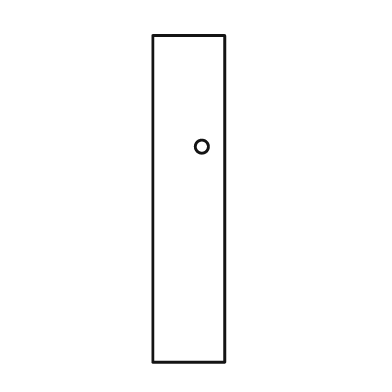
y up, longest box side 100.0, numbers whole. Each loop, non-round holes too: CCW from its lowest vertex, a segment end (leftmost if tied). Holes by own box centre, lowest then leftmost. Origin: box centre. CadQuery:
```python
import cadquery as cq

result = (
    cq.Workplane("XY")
    .moveTo(-11.0, -50.0)
    .lineTo(11.0, -50.0)
    .lineTo(11.0, 50.0)
    .lineTo(-11.0, 50.0)
    .close()
    .moveTo(4.0, 16.0)
    .circle(2.0)
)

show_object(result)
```